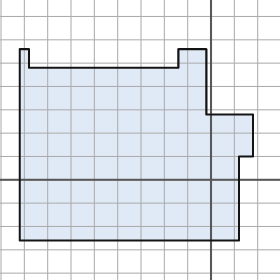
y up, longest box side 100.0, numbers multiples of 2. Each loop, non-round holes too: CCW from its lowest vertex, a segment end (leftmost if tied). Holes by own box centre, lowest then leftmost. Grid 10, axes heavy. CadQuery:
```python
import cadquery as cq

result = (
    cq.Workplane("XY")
    .moveTo(-82.0, -26.0)
    .lineTo(12.0, -26.0)
    .lineTo(12.0, 10.0)
    .lineTo(18.0, 10.0)
    .lineTo(18.0, 28.0)
    .lineTo(-2.0, 28.0)
    .lineTo(-2.0, 56.0)
    .lineTo(-14.0, 56.0)
    .lineTo(-14.0, 48.0)
    .lineTo(-78.0, 48.0)
    .lineTo(-78.0, 56.0)
    .lineTo(-82.0, 56.0)
    .close()
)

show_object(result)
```